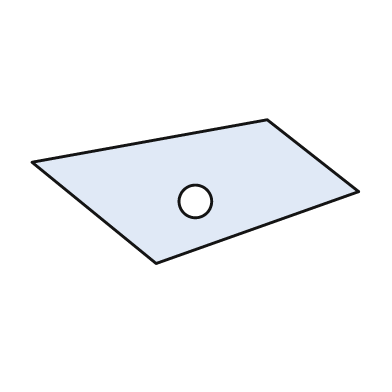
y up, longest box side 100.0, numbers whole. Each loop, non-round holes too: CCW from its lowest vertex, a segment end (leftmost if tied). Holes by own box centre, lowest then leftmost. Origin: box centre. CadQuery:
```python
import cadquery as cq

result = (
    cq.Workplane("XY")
    .moveTo(-12.0, -22.0)
    .lineTo(50.0, 0.0)
    .lineTo(22.0, 22.0)
    .lineTo(-50.0, 9.0)
    .close()
    .moveTo(0.0, -3.0)
    .circle(5.0)
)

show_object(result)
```